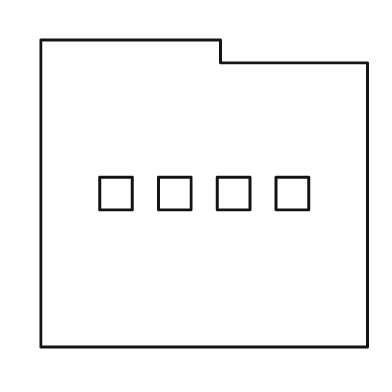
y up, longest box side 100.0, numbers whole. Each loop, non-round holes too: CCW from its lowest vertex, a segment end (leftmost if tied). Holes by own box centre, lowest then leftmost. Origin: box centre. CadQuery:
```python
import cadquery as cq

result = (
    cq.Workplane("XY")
    .moveTo(-50.0, -47.0)
    .lineTo(50.0, -47.0)
    .lineTo(50.0, 40.0)
    .lineTo(5.0, 40.0)
    .lineTo(5.0, 47.0)
    .lineTo(-50.0, 47.0)
    .close()
    .moveTo(-32.0, -5.0)
    .lineTo(-22.0, -5.0)
    .lineTo(-22.0, 5.0)
    .lineTo(-32.0, 5.0)
    .close()
    .moveTo(-14.0, -5.0)
    .lineTo(-4.0, -5.0)
    .lineTo(-4.0, 5.0)
    .lineTo(-14.0, 5.0)
    .close()
    .moveTo(4.0, -5.0)
    .lineTo(14.0, -5.0)
    .lineTo(14.0, 5.0)
    .lineTo(4.0, 5.0)
    .close()
    .moveTo(22.0, -5.0)
    .lineTo(32.0, -5.0)
    .lineTo(32.0, 5.0)
    .lineTo(22.0, 5.0)
    .close()
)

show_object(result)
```